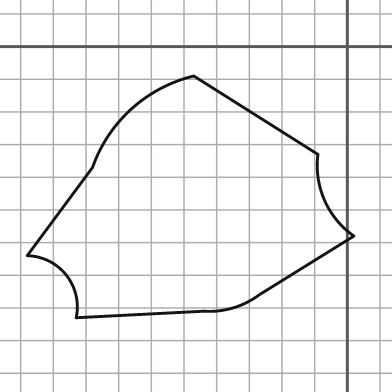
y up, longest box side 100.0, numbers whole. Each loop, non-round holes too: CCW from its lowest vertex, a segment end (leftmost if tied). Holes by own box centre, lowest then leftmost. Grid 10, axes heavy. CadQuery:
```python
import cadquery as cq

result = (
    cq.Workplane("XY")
    .moveTo(-83.0, -83.0)
    .lineTo(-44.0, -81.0)
    .threePointArc((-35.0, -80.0), (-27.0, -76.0))
    .lineTo(2.0, -58.0)
    .threePointArc((-7.0, -47.0), (-9.0, -33.0))
    .lineTo(-47.0, -9.0)
    .threePointArc((-66.0, -19.0), (-78.0, -37.0))
    .lineTo(-98.0, -64.0)
    .threePointArc((-86.0, -70.0), (-83.0, -83.0))
    .close()
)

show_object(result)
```